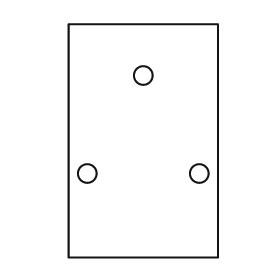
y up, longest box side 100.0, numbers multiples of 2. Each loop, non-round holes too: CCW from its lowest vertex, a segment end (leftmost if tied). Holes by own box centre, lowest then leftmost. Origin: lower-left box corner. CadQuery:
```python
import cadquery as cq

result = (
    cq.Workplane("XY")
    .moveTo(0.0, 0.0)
    .lineTo(64.0, 0.0)
    .lineTo(64.0, 100.0)
    .lineTo(0.0, 100.0)
    .close()
    .moveTo(8.0, 36.0)
    .circle(4.0)
    .moveTo(56.0, 36.0)
    .circle(4.0)
    .moveTo(32.0, 78.0)
    .circle(4.0)
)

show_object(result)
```